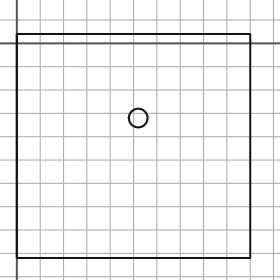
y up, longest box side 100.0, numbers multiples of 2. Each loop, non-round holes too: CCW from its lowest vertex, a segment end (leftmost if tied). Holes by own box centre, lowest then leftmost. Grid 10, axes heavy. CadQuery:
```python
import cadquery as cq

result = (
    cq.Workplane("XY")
    .moveTo(0.0, -92.0)
    .lineTo(100.0, -92.0)
    .lineTo(100.0, 4.0)
    .lineTo(0.0, 4.0)
    .close()
    .moveTo(52.0, -32.0)
    .circle(4.0)
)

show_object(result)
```